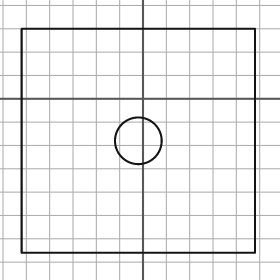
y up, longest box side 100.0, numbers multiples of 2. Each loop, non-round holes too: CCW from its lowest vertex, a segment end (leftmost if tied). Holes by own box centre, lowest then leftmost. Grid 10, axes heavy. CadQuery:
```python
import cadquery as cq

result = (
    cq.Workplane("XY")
    .moveTo(-52.0, -66.0)
    .lineTo(48.0, -66.0)
    .lineTo(48.0, 30.0)
    .lineTo(-52.0, 30.0)
    .close()
    .moveTo(-2.0, -18.0)
    .circle(10.0)
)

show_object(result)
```